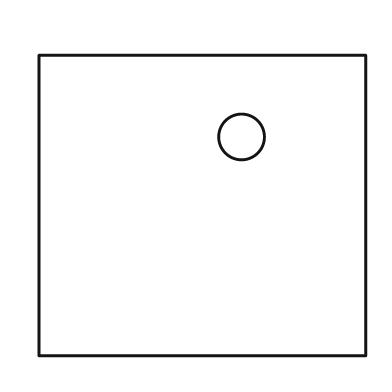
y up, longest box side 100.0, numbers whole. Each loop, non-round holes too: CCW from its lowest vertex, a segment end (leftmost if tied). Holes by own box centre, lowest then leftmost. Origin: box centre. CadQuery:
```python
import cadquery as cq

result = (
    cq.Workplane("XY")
    .moveTo(-50.0, -46.0)
    .lineTo(50.0, -46.0)
    .lineTo(50.0, 46.0)
    .lineTo(-50.0, 46.0)
    .close()
    .moveTo(12.0, 21.0)
    .circle(7.0)
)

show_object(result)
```